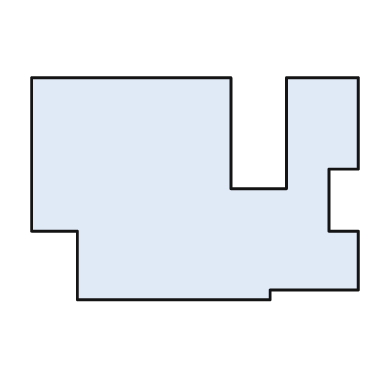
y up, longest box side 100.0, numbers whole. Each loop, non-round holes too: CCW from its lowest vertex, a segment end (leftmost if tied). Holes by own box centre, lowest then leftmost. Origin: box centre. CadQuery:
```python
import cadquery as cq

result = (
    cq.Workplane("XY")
    .moveTo(-36.0, -34.0)
    .lineTo(23.0, -34.0)
    .lineTo(23.0, -31.0)
    .lineTo(50.0, -31.0)
    .lineTo(50.0, -13.0)
    .lineTo(41.0, -13.0)
    .lineTo(41.0, 6.0)
    .lineTo(50.0, 6.0)
    .lineTo(50.0, 34.0)
    .lineTo(28.0, 34.0)
    .lineTo(28.0, 0.0)
    .lineTo(11.0, 0.0)
    .lineTo(11.0, 34.0)
    .lineTo(-50.0, 34.0)
    .lineTo(-50.0, -13.0)
    .lineTo(-36.0, -13.0)
    .close()
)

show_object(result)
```